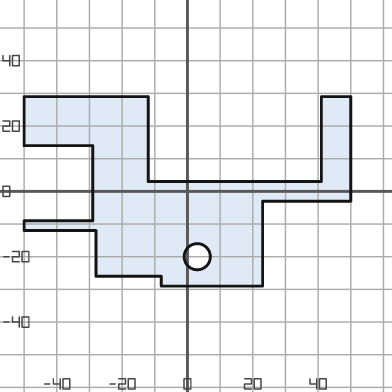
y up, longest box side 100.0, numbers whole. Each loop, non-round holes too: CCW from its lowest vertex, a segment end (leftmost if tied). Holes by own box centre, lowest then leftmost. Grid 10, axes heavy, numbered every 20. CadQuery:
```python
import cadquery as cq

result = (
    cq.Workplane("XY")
    .moveTo(-8.0, -29.0)
    .lineTo(23.0, -29.0)
    .lineTo(23.0, -3.0)
    .lineTo(50.0, -3.0)
    .lineTo(50.0, 29.0)
    .lineTo(41.0, 29.0)
    .lineTo(41.0, 3.0)
    .lineTo(-12.0, 3.0)
    .lineTo(-12.0, 29.0)
    .lineTo(-50.0, 29.0)
    .lineTo(-50.0, 14.0)
    .lineTo(-29.0, 14.0)
    .lineTo(-29.0, -9.0)
    .lineTo(-50.0, -9.0)
    .lineTo(-50.0, -12.0)
    .lineTo(-28.0, -12.0)
    .lineTo(-28.0, -26.0)
    .lineTo(-8.0, -26.0)
    .close()
    .moveTo(3.0, -20.0)
    .circle(4.0)
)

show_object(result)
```